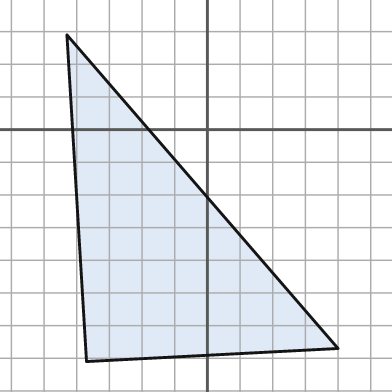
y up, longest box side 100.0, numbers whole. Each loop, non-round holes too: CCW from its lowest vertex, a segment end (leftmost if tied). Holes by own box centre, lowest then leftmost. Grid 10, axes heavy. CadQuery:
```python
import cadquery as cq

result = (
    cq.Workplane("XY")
    .moveTo(-37.0, -71.0)
    .lineTo(40.0, -67.0)
    .lineTo(-43.0, 29.0)
    .close()
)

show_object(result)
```